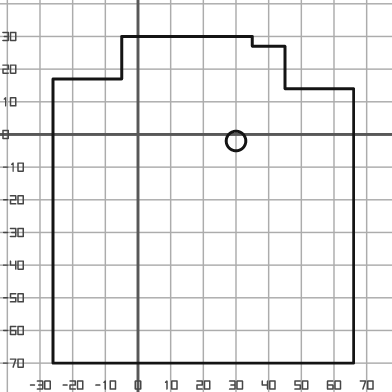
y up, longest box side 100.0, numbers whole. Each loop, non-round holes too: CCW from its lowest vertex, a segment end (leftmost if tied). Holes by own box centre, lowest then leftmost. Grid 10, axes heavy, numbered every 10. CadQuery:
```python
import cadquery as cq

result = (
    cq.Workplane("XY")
    .moveTo(-26.0, -70.0)
    .lineTo(66.0, -70.0)
    .lineTo(66.0, 14.0)
    .lineTo(45.0, 14.0)
    .lineTo(45.0, 27.0)
    .lineTo(35.0, 27.0)
    .lineTo(35.0, 30.0)
    .lineTo(-5.0, 30.0)
    .lineTo(-5.0, 17.0)
    .lineTo(-26.0, 17.0)
    .close()
    .moveTo(30.0, -2.0)
    .circle(3.0)
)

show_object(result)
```